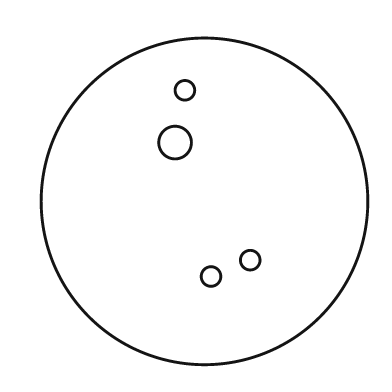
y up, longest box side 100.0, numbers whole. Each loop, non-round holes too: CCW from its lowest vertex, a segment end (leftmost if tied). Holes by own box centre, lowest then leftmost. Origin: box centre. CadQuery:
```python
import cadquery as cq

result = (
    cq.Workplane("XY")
    .moveTo(0.0, 0.0)
    .circle(50.0)
    .moveTo(2.0, -23.0)
    .circle(3.0)
    .moveTo(14.0, -18.0)
    .circle(3.0)
    .moveTo(-9.0, 18.0)
    .circle(5.0)
    .moveTo(-6.0, 34.0)
    .circle(3.0)
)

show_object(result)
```